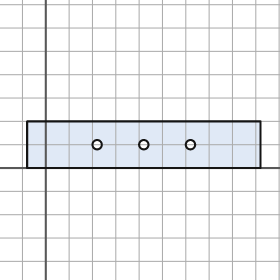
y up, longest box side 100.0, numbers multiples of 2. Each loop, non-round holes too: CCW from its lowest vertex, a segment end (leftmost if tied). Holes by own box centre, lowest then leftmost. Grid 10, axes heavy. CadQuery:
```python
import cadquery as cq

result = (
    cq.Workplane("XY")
    .moveTo(-8.0, 0.0)
    .lineTo(92.0, 0.0)
    .lineTo(92.0, 20.0)
    .lineTo(-8.0, 20.0)
    .close()
    .moveTo(22.0, 10.0)
    .circle(2.0)
    .moveTo(42.0, 10.0)
    .circle(2.0)
    .moveTo(62.0, 10.0)
    .circle(2.0)
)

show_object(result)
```